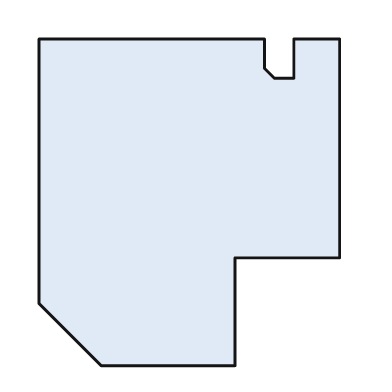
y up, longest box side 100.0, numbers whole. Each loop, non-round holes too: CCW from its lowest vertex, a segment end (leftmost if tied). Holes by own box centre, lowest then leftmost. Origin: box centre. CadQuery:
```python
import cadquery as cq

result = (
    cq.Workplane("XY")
    .moveTo(-27.0, -50.0)
    .lineTo(14.0, -50.0)
    .lineTo(14.0, -17.0)
    .lineTo(46.0, -17.0)
    .lineTo(46.0, 50.0)
    .lineTo(32.0, 50.0)
    .lineTo(32.0, 38.0)
    .lineTo(26.0, 38.0)
    .lineTo(23.0, 41.0)
    .lineTo(23.0, 50.0)
    .lineTo(-46.0, 50.0)
    .lineTo(-46.0, -31.0)
    .close()
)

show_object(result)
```